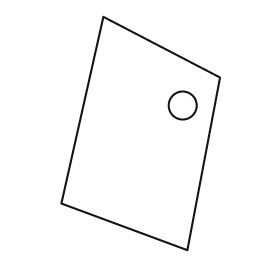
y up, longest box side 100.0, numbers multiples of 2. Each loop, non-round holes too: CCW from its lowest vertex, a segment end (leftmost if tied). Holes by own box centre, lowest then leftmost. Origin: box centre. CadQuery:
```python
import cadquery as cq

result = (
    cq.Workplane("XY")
    .moveTo(20.0, -50.0)
    .lineTo(34.0, 24.0)
    .lineTo(-16.0, 50.0)
    .lineTo(-34.0, -30.0)
    .close()
    .moveTo(18.0, 12.0)
    .circle(6.0)
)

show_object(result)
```